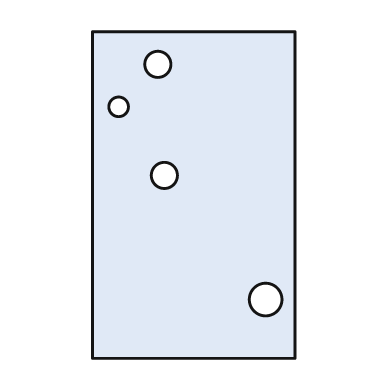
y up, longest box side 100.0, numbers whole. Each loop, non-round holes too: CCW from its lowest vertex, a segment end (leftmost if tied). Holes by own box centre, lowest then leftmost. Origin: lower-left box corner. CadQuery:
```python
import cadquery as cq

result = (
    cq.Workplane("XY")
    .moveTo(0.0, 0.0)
    .lineTo(62.0, 0.0)
    .lineTo(62.0, 100.0)
    .lineTo(0.0, 100.0)
    .close()
    .moveTo(53.0, 18.0)
    .circle(5.0)
    .moveTo(22.0, 56.0)
    .circle(4.0)
    .moveTo(8.0, 77.0)
    .circle(3.0)
    .moveTo(20.0, 90.0)
    .circle(4.0)
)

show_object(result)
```